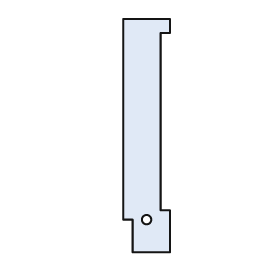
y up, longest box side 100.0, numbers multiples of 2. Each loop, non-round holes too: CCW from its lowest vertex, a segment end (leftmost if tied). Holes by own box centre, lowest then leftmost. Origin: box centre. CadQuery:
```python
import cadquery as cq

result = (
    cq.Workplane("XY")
    .moveTo(-6.0, -50.0)
    .lineTo(10.0, -50.0)
    .lineTo(10.0, -32.0)
    .lineTo(6.0, -32.0)
    .lineTo(6.0, 44.0)
    .lineTo(10.0, 44.0)
    .lineTo(10.0, 50.0)
    .lineTo(-10.0, 50.0)
    .lineTo(-10.0, -36.0)
    .lineTo(-6.0, -36.0)
    .close()
    .moveTo(0.0, -36.0)
    .circle(2.0)
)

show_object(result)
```